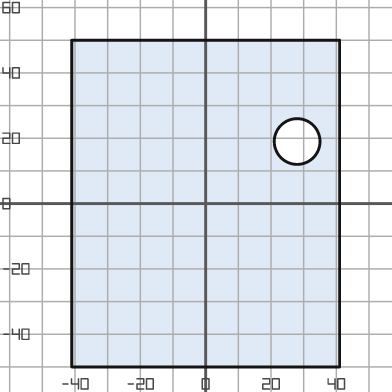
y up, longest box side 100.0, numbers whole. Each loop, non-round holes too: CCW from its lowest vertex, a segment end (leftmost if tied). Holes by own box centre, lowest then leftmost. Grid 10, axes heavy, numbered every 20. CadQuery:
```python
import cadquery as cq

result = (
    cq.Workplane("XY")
    .moveTo(-41.0, -50.0)
    .lineTo(41.0, -50.0)
    .lineTo(41.0, 50.0)
    .lineTo(-41.0, 50.0)
    .close()
    .moveTo(28.0, 19.0)
    .circle(7.0)
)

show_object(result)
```